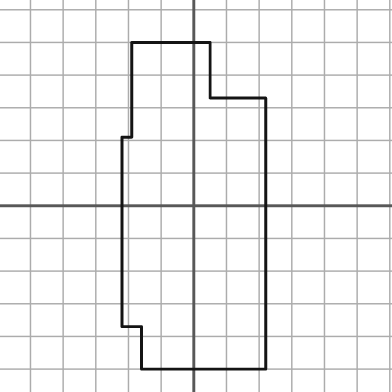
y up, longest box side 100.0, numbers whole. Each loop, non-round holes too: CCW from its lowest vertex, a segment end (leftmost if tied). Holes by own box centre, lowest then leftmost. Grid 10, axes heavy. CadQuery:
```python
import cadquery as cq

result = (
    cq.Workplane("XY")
    .moveTo(-16.0, -50.0)
    .lineTo(22.0, -50.0)
    .lineTo(22.0, 33.0)
    .lineTo(5.0, 33.0)
    .lineTo(5.0, 50.0)
    .lineTo(-19.0, 50.0)
    .lineTo(-19.0, 21.0)
    .lineTo(-22.0, 21.0)
    .lineTo(-22.0, -37.0)
    .lineTo(-16.0, -37.0)
    .close()
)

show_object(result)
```